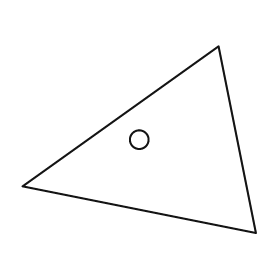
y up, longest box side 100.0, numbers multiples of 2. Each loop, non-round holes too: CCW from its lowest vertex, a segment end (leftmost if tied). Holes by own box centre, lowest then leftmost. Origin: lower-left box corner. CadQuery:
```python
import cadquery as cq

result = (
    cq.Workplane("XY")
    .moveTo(100.0, 0.0)
    .lineTo(84.0, 80.0)
    .lineTo(0.0, 20.0)
    .close()
    .moveTo(50.0, 40.0)
    .circle(4.0)
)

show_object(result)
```